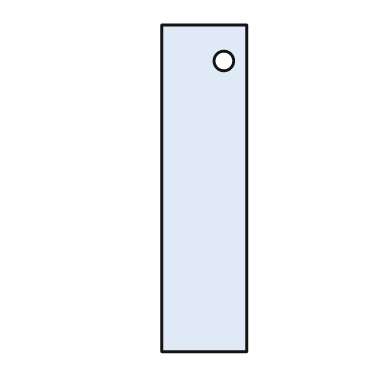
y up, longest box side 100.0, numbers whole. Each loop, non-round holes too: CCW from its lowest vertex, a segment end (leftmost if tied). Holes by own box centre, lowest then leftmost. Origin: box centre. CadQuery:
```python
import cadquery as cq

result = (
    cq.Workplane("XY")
    .moveTo(-13.0, -50.0)
    .lineTo(13.0, -50.0)
    .lineTo(13.0, 50.0)
    .lineTo(-13.0, 50.0)
    .close()
    .moveTo(6.0, 39.0)
    .circle(3.0)
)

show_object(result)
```